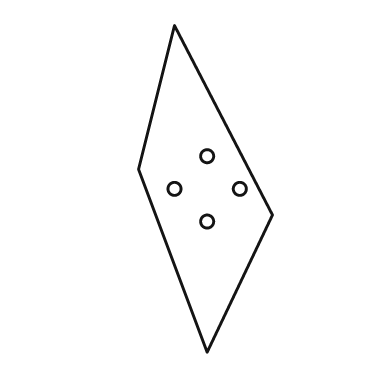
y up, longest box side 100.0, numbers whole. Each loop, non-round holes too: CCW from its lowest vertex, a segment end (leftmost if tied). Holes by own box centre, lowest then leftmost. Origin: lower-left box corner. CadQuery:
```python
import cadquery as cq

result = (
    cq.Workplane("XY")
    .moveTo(21.0, 0.0)
    .lineTo(41.0, 42.0)
    .lineTo(11.0, 100.0)
    .lineTo(0.0, 56.0)
    .close()
    .moveTo(21.0, 40.0)
    .circle(2.0)
    .moveTo(11.0, 50.0)
    .circle(2.0)
    .moveTo(31.0, 50.0)
    .circle(2.0)
    .moveTo(21.0, 60.0)
    .circle(2.0)
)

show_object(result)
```